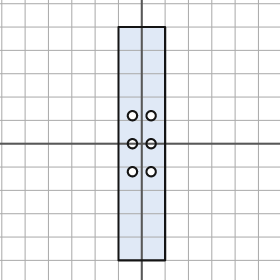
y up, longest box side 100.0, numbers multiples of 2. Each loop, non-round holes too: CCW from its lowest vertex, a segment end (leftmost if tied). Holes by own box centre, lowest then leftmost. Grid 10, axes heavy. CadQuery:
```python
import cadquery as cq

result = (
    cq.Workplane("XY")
    .moveTo(-10.0, -50.0)
    .lineTo(10.0, -50.0)
    .lineTo(10.0, 50.0)
    .lineTo(-10.0, 50.0)
    .close()
    .moveTo(-4.0, -12.0)
    .circle(2.0)
    .moveTo(4.0, -12.0)
    .circle(2.0)
    .moveTo(-4.0, 0.0)
    .circle(2.0)
    .moveTo(4.0, 0.0)
    .circle(2.0)
    .moveTo(-4.0, 12.0)
    .circle(2.0)
    .moveTo(4.0, 12.0)
    .circle(2.0)
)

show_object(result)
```